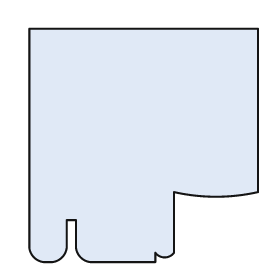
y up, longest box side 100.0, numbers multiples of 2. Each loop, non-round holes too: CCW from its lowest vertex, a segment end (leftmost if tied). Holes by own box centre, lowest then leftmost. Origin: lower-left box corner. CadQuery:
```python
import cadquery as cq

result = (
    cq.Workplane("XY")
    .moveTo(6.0, 0.0)
    .lineTo(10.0, 0.0)
    .threePointArc((14.0, 2.0), (16.0, 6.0))
    .lineTo(16.0, 18.0)
    .lineTo(20.0, 18.0)
    .lineTo(20.0, 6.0)
    .threePointArc((22.0, 2.0), (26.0, 0.0))
    .lineTo(54.0, 0.0)
    .lineTo(54.0, 4.0)
    .threePointArc((58.0, 2.0), (62.0, 4.0))
    .lineTo(62.0, 30.0)
    .threePointArc((80.0, 28.0), (98.0, 30.0))
    .lineTo(98.0, 100.0)
    .lineTo(0.0, 100.0)
    .lineTo(0.0, 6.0)
    .threePointArc((2.0, 2.0), (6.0, 0.0))
    .close()
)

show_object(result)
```